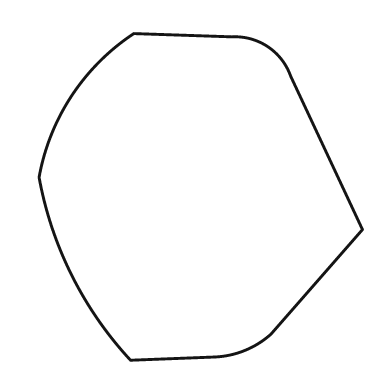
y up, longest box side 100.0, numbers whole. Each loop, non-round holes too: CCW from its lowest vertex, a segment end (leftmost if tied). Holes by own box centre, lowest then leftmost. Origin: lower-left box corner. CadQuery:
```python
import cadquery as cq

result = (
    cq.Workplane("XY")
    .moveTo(28.0, 0.0)
    .lineTo(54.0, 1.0)
    .threePointArc((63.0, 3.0), (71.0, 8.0))
    .lineTo(99.0, 40.0)
    .lineTo(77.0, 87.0)
    .threePointArc((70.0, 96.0), (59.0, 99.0))
    .lineTo(29.0, 100.0)
    .threePointArc((10.0, 81.0), (0.0, 56.0))
    .threePointArc((10.0, 26.0), (28.0, 0.0))
    .close()
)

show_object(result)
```